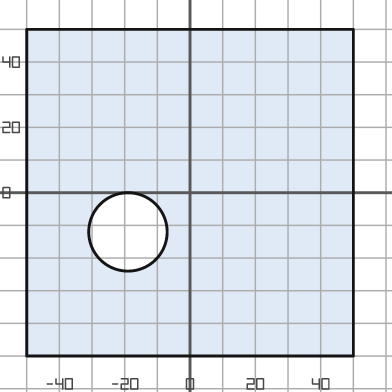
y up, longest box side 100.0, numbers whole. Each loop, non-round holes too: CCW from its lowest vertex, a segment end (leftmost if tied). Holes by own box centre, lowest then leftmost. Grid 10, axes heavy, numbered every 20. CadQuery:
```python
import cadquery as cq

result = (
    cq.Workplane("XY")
    .moveTo(-50.0, -50.0)
    .lineTo(50.0, -50.0)
    .lineTo(50.0, 50.0)
    .lineTo(-50.0, 50.0)
    .close()
    .moveTo(-19.0, -12.0)
    .circle(12.0)
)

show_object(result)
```